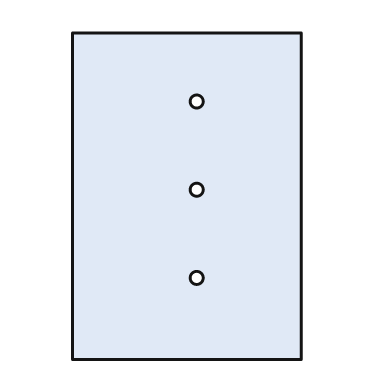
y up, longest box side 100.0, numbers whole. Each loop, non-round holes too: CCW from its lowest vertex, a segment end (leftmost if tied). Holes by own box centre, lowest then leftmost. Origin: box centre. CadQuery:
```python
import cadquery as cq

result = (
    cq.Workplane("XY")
    .moveTo(-35.0, -50.0)
    .lineTo(35.0, -50.0)
    .lineTo(35.0, 50.0)
    .lineTo(-35.0, 50.0)
    .close()
    .moveTo(3.0, -25.0)
    .circle(2.0)
    .moveTo(3.0, 2.0)
    .circle(2.0)
    .moveTo(3.0, 29.0)
    .circle(2.0)
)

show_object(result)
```